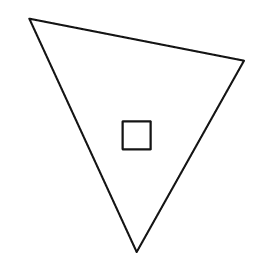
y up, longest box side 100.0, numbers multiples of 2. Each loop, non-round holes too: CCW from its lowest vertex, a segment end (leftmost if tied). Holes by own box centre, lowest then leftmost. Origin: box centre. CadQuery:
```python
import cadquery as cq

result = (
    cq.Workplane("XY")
    .moveTo(0.0, -50.0)
    .lineTo(46.0, 32.0)
    .lineTo(-46.0, 50.0)
    .close()
    .moveTo(-6.0, -6.0)
    .lineTo(6.0, -6.0)
    .lineTo(6.0, 6.0)
    .lineTo(-6.0, 6.0)
    .close()
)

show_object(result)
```